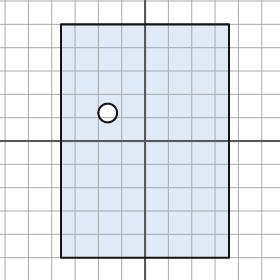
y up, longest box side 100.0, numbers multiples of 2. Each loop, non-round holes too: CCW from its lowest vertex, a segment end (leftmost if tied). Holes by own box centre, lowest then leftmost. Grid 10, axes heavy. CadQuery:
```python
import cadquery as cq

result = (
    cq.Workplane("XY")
    .moveTo(-36.0, -50.0)
    .lineTo(36.0, -50.0)
    .lineTo(36.0, 50.0)
    .lineTo(-36.0, 50.0)
    .close()
    .moveTo(-16.0, 12.0)
    .circle(4.0)
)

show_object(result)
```